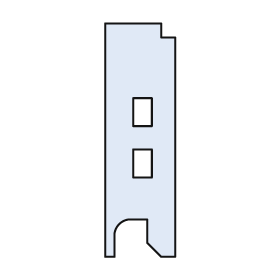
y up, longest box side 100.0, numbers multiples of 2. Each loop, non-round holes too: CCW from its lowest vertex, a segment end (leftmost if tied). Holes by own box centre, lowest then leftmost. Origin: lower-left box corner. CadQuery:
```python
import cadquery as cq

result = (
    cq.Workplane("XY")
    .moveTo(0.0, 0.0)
    .lineTo(4.0, 0.0)
    .lineTo(4.0, 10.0)
    .threePointArc((6.0, 14.0), (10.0, 16.0))
    .lineTo(18.0, 16.0)
    .lineTo(18.0, 6.0)
    .lineTo(24.0, 0.0)
    .lineTo(30.0, 0.0)
    .lineTo(30.0, 94.0)
    .lineTo(24.0, 94.0)
    .lineTo(24.0, 100.0)
    .lineTo(0.0, 100.0)
    .close()
    .moveTo(12.0, 34.0)
    .lineTo(20.0, 34.0)
    .lineTo(20.0, 46.0)
    .lineTo(12.0, 46.0)
    .close()
    .moveTo(12.0, 56.0)
    .lineTo(20.0, 56.0)
    .lineTo(20.0, 68.0)
    .lineTo(12.0, 68.0)
    .close()
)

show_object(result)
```